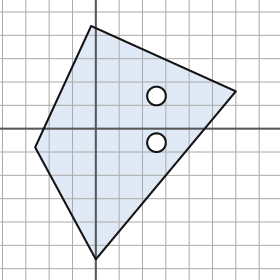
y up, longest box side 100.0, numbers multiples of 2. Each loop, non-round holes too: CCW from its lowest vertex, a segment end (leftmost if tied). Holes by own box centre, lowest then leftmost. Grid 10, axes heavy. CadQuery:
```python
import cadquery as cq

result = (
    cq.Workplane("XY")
    .moveTo(0.0, -56.0)
    .lineTo(60.0, 16.0)
    .lineTo(-2.0, 44.0)
    .lineTo(-26.0, -8.0)
    .close()
    .moveTo(26.0, -6.0)
    .circle(4.0)
    .moveTo(26.0, 14.0)
    .circle(4.0)
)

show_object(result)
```